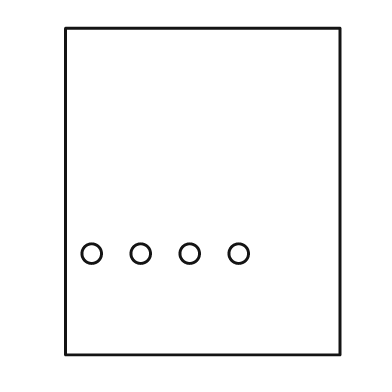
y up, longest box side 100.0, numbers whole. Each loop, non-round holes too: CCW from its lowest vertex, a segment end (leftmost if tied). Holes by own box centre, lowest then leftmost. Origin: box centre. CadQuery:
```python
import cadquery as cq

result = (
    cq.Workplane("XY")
    .moveTo(-42.0, -50.0)
    .lineTo(42.0, -50.0)
    .lineTo(42.0, 50.0)
    .lineTo(-42.0, 50.0)
    .close()
    .moveTo(-34.0, -19.0)
    .circle(3.0)
    .moveTo(-19.0, -19.0)
    .circle(3.0)
    .moveTo(-4.0, -19.0)
    .circle(3.0)
    .moveTo(11.0, -19.0)
    .circle(3.0)
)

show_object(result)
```